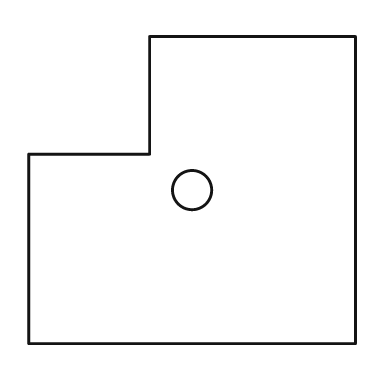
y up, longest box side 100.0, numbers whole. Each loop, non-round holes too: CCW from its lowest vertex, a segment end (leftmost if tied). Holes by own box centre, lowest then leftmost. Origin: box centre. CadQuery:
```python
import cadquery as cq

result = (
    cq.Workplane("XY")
    .moveTo(-50.0, -47.0)
    .lineTo(50.0, -47.0)
    .lineTo(50.0, 47.0)
    .lineTo(-13.0, 47.0)
    .lineTo(-13.0, 11.0)
    .lineTo(-50.0, 11.0)
    .close()
    .moveTo(0.0, 0.0)
    .circle(6.0)
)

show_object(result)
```